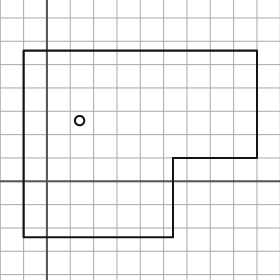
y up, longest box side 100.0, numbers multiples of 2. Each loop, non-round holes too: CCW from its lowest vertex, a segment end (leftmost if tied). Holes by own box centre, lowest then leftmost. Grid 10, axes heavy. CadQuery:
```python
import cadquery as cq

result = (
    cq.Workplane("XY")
    .moveTo(-10.0, -24.0)
    .lineTo(54.0, -24.0)
    .lineTo(54.0, 10.0)
    .lineTo(90.0, 10.0)
    .lineTo(90.0, 56.0)
    .lineTo(-10.0, 56.0)
    .close()
    .moveTo(14.0, 26.0)
    .circle(2.0)
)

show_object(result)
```